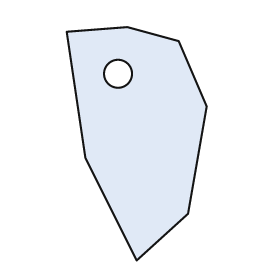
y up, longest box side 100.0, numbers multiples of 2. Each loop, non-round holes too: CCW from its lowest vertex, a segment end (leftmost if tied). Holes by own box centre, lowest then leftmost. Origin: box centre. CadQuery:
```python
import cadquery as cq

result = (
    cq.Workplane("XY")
    .moveTo(0.0, -50.0)
    .lineTo(22.0, -30.0)
    .lineTo(30.0, 16.0)
    .lineTo(18.0, 44.0)
    .lineTo(-4.0, 50.0)
    .lineTo(-30.0, 48.0)
    .lineTo(-22.0, -6.0)
    .close()
    .moveTo(-8.0, 30.0)
    .circle(6.0)
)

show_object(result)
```